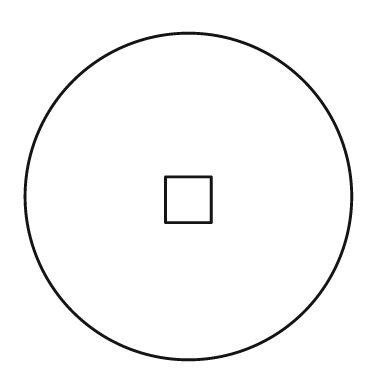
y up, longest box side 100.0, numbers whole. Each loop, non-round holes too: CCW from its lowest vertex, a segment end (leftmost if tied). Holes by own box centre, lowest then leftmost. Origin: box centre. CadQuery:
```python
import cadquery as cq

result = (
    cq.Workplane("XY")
    .moveTo(0.0, 0.0)
    .circle(50.0)
    .moveTo(-7.0, -8.0)
    .lineTo(7.0, -8.0)
    .lineTo(7.0, 6.0)
    .lineTo(-7.0, 6.0)
    .close()
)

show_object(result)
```